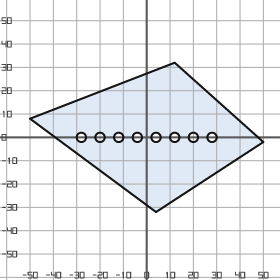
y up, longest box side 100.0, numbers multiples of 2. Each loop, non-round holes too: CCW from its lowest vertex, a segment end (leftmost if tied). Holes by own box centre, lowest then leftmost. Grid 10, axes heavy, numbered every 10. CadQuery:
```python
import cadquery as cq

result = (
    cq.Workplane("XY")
    .moveTo(4.0, -32.0)
    .lineTo(50.0, -2.0)
    .lineTo(12.0, 32.0)
    .lineTo(-50.0, 8.0)
    .close()
    .moveTo(-28.0, 0.0)
    .circle(2.0)
    .moveTo(-20.0, 0.0)
    .circle(2.0)
    .moveTo(-12.0, 0.0)
    .circle(2.0)
    .moveTo(-4.0, 0.0)
    .circle(2.0)
    .moveTo(4.0, 0.0)
    .circle(2.0)
    .moveTo(12.0, 0.0)
    .circle(2.0)
    .moveTo(20.0, 0.0)
    .circle(2.0)
    .moveTo(28.0, 0.0)
    .circle(2.0)
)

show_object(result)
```